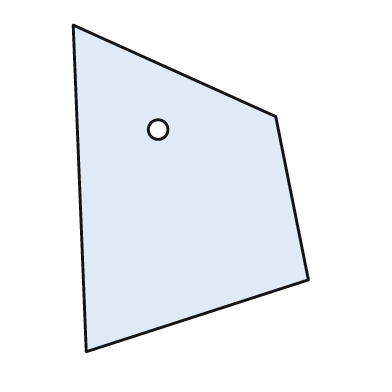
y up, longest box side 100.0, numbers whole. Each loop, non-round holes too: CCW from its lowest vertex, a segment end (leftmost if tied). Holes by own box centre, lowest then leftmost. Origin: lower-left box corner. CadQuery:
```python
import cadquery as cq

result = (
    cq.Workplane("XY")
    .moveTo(4.0, 0.0)
    .lineTo(72.0, 22.0)
    .lineTo(62.0, 72.0)
    .lineTo(0.0, 100.0)
    .close()
    .moveTo(26.0, 68.0)
    .circle(3.0)
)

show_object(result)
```